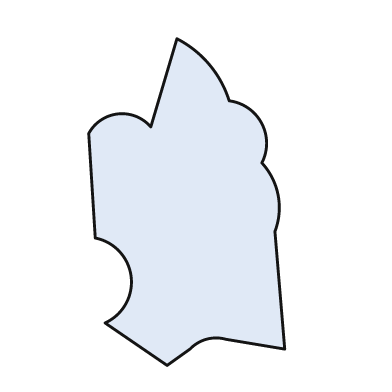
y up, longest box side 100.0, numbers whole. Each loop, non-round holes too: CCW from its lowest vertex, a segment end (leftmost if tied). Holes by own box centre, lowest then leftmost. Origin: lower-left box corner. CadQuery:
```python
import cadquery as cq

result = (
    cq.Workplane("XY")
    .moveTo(24.0, 0.0)
    .lineTo(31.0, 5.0)
    .threePointArc((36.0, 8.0), (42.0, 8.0))
    .lineTo(60.0, 5.0)
    .lineTo(57.0, 41.0)
    .threePointArc((58.0, 52.0), (53.0, 62.0))
    .threePointArc((53.0, 74.0), (43.0, 81.0))
    .threePointArc((37.0, 92.0), (27.0, 100.0))
    .lineTo(19.0, 73.0)
    .threePointArc((9.0, 77.0), (0.0, 71.0))
    .lineTo(2.0, 39.0)
    .threePointArc((13.0, 27.0), (5.0, 13.0))
    .close()
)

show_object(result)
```